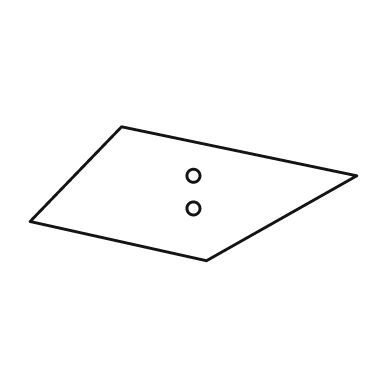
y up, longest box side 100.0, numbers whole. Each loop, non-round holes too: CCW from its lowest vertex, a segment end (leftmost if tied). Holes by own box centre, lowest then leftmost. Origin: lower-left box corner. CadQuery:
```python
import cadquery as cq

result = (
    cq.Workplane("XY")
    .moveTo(54.0, 0.0)
    .lineTo(100.0, 26.0)
    .lineTo(28.0, 41.0)
    .lineTo(0.0, 12.0)
    .close()
    .moveTo(50.0, 16.0)
    .circle(2.0)
    .moveTo(50.0, 26.0)
    .circle(2.0)
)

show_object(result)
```